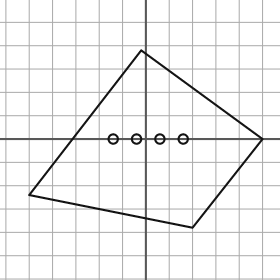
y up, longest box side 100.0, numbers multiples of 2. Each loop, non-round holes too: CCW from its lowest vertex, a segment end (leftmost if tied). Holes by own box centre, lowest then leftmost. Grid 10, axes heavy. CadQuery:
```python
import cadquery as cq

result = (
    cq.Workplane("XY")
    .moveTo(20.0, -38.0)
    .lineTo(50.0, 0.0)
    .lineTo(-2.0, 38.0)
    .lineTo(-50.0, -24.0)
    .close()
    .moveTo(-14.0, 0.0)
    .circle(2.0)
    .moveTo(-4.0, 0.0)
    .circle(2.0)
    .moveTo(6.0, 0.0)
    .circle(2.0)
    .moveTo(16.0, 0.0)
    .circle(2.0)
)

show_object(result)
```